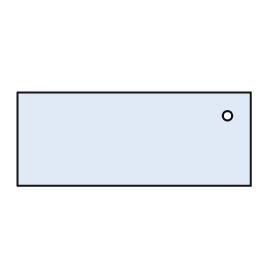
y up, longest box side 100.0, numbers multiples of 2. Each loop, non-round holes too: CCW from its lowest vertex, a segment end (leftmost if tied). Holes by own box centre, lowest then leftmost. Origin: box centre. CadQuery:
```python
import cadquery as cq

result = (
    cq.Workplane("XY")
    .moveTo(-50.0, -20.0)
    .lineTo(50.0, -20.0)
    .lineTo(50.0, 20.0)
    .lineTo(-50.0, 20.0)
    .close()
    .moveTo(40.0, 10.0)
    .circle(2.0)
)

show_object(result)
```